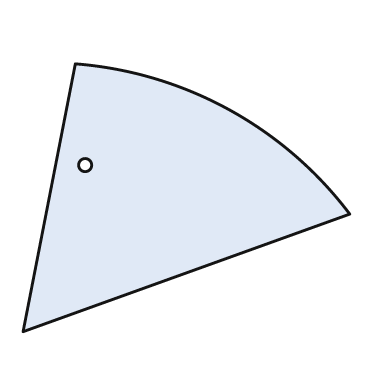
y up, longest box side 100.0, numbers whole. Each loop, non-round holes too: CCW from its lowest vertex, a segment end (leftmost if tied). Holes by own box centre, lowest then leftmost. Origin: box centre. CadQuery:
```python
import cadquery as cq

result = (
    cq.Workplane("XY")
    .moveTo(-50.0, -41.0)
    .lineTo(50.0, -5.0)
    .threePointArc((13.0, 27.0), (-34.0, 41.0))
    .close()
    .moveTo(-31.0, 10.0)
    .circle(2.0)
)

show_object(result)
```